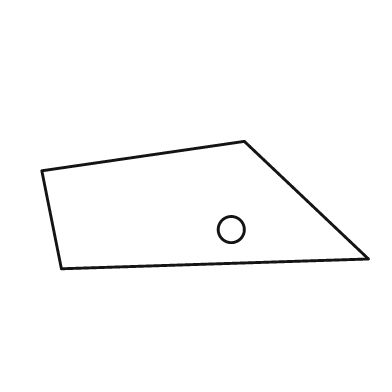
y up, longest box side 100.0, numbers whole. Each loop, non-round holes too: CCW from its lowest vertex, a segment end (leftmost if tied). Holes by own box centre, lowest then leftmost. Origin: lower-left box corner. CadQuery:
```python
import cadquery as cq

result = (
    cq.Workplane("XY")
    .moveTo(6.0, 0.0)
    .lineTo(100.0, 3.0)
    .lineTo(62.0, 39.0)
    .lineTo(0.0, 30.0)
    .close()
    .moveTo(58.0, 12.0)
    .circle(4.0)
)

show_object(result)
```